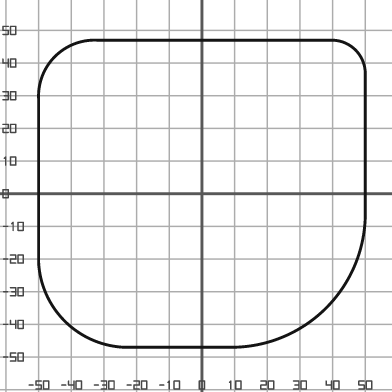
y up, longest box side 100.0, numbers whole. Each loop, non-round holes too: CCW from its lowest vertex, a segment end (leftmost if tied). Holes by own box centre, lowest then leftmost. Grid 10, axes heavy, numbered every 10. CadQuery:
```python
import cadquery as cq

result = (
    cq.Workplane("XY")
    .moveTo(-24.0, -47.0)
    .lineTo(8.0, -47.0)
    .threePointArc((38.0, -35.0), (50.0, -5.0))
    .lineTo(50.0, 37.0)
    .threePointArc((47.0, 44.0), (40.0, 47.0))
    .lineTo(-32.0, 47.0)
    .threePointArc((-45.0, 42.0), (-50.0, 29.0))
    .lineTo(-50.0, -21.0)
    .threePointArc((-42.0, -39.0), (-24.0, -47.0))
    .close()
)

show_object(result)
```